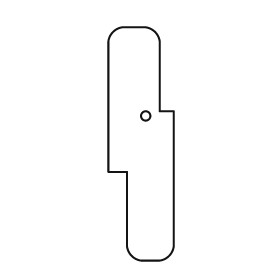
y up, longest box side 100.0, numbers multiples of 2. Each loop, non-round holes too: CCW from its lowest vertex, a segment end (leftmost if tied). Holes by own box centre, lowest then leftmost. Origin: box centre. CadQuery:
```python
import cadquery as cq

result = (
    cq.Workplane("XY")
    .moveTo(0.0, -50.0)
    .lineTo(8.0, -50.0)
    .threePointArc((12.0, -48.0), (14.0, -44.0))
    .lineTo(14.0, 14.0)
    .lineTo(8.0, 14.0)
    .lineTo(8.0, 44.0)
    .threePointArc((6.0, 48.0), (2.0, 50.0))
    .lineTo(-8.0, 50.0)
    .threePointArc((-12.0, 48.0), (-14.0, 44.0))
    .lineTo(-14.0, -12.0)
    .lineTo(-6.0, -12.0)
    .lineTo(-6.0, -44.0)
    .threePointArc((-4.0, -48.0), (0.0, -50.0))
    .close()
    .moveTo(2.0, 12.0)
    .circle(2.0)
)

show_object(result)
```